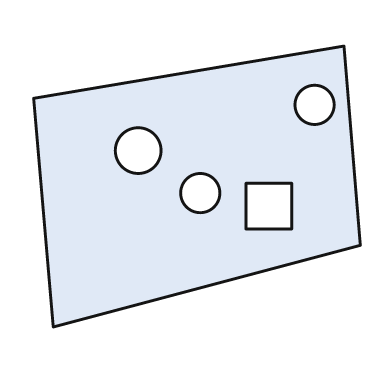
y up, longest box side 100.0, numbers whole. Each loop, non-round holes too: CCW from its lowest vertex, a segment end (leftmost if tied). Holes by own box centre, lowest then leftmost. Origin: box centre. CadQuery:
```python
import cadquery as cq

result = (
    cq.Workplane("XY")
    .moveTo(-44.0, -43.0)
    .lineTo(50.0, -18.0)
    .lineTo(45.0, 43.0)
    .lineTo(-50.0, 27.0)
    .close()
    .moveTo(15.0, -13.0)
    .lineTo(29.0, -13.0)
    .lineTo(29.0, 1.0)
    .lineTo(15.0, 1.0)
    .close()
    .moveTo(1.0, -2.0)
    .circle(6.0)
    .moveTo(-18.0, 11.0)
    .circle(7.0)
    .moveTo(36.0, 25.0)
    .circle(6.0)
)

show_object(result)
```